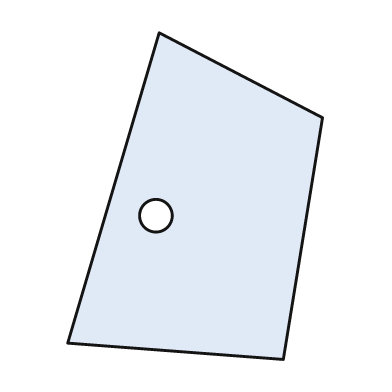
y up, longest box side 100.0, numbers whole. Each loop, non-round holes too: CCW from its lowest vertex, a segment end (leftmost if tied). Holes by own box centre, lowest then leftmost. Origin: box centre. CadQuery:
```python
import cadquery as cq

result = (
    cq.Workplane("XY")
    .moveTo(27.0, -50.0)
    .lineTo(39.0, 24.0)
    .lineTo(-11.0, 50.0)
    .lineTo(-39.0, -45.0)
    .close()
    .moveTo(-12.0, -6.0)
    .circle(5.0)
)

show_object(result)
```